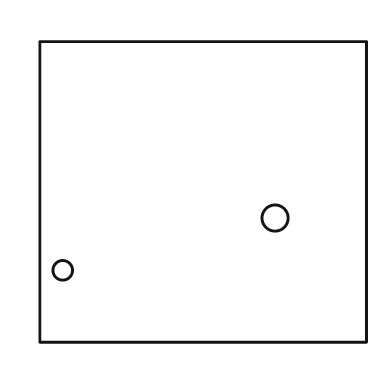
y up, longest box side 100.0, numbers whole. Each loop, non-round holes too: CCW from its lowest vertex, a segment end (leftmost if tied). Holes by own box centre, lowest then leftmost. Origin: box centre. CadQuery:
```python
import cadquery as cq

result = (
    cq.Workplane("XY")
    .moveTo(-50.0, -46.0)
    .lineTo(50.0, -46.0)
    .lineTo(50.0, 46.0)
    .lineTo(-50.0, 46.0)
    .close()
    .moveTo(-43.0, -24.0)
    .circle(3.0)
    .moveTo(22.0, -8.0)
    .circle(4.0)
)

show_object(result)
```